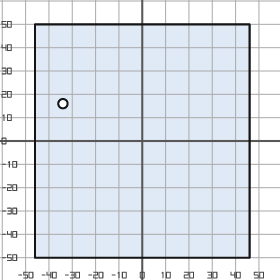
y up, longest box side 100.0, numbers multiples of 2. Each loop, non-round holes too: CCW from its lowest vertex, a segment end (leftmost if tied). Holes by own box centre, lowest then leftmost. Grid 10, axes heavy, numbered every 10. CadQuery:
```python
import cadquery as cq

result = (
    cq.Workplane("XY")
    .moveTo(-46.0, -50.0)
    .lineTo(46.0, -50.0)
    .lineTo(46.0, 50.0)
    .lineTo(-46.0, 50.0)
    .close()
    .moveTo(-34.0, 16.0)
    .circle(2.0)
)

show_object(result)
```